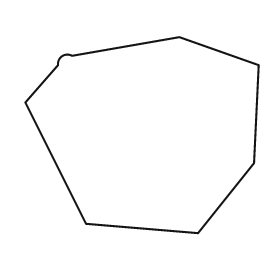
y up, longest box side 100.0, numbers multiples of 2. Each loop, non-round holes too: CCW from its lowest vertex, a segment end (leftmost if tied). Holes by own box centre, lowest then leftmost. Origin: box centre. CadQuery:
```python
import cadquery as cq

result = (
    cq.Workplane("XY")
    .moveTo(24.0, -42.0)
    .lineTo(48.0, -12.0)
    .lineTo(50.0, 30.0)
    .lineTo(16.0, 42.0)
    .lineTo(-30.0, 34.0)
    .threePointArc((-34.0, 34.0), (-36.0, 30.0))
    .lineTo(-50.0, 14.0)
    .lineTo(-24.0, -38.0)
    .close()
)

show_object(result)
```